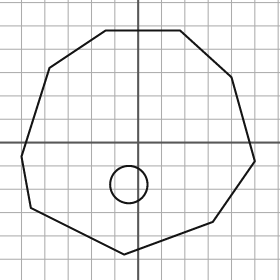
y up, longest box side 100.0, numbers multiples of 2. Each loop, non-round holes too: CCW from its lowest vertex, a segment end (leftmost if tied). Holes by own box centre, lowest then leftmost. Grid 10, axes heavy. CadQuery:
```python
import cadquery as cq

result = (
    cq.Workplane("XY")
    .moveTo(-6.0, -48.0)
    .lineTo(32.0, -34.0)
    .lineTo(50.0, -8.0)
    .lineTo(40.0, 28.0)
    .lineTo(18.0, 48.0)
    .lineTo(-14.0, 48.0)
    .lineTo(-38.0, 32.0)
    .lineTo(-50.0, -6.0)
    .lineTo(-46.0, -28.0)
    .close()
    .moveTo(-4.0, -18.0)
    .circle(8.0)
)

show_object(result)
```